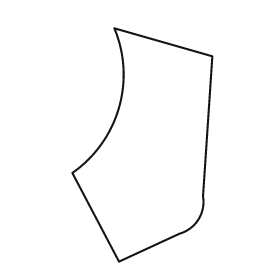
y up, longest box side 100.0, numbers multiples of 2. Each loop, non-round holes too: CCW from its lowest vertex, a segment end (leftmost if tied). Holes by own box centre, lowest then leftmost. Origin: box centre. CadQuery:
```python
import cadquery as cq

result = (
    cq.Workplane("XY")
    .moveTo(-10.0, -50.0)
    .lineTo(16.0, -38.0)
    .threePointArc((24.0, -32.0), (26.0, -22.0))
    .lineTo(30.0, 38.0)
    .lineTo(-12.0, 50.0)
    .threePointArc((-10.0, 16.0), (-30.0, -12.0))
    .close()
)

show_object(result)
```